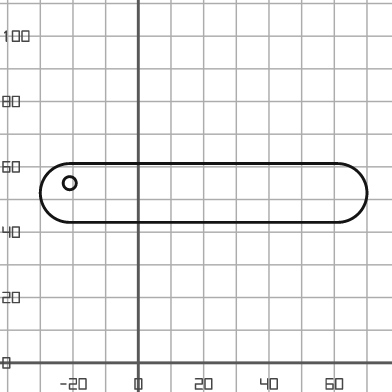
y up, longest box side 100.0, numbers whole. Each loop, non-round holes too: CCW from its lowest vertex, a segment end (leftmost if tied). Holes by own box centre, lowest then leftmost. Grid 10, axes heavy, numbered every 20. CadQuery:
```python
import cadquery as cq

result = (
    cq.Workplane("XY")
    .moveTo(-21.0, 43.0)
    .lineTo(61.0, 43.0)
    .threePointArc((70.0, 52.0), (61.0, 61.0))
    .lineTo(-21.0, 61.0)
    .threePointArc((-30.0, 52.0), (-21.0, 43.0))
    .close()
    .moveTo(-21.0, 55.0)
    .circle(2.0)
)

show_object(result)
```